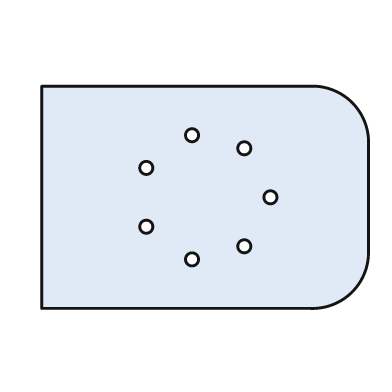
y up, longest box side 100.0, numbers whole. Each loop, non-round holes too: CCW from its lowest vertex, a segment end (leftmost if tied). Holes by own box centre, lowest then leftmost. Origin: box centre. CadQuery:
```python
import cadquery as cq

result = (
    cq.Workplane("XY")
    .moveTo(-50.0, -34.0)
    .lineTo(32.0, -34.0)
    .threePointArc((45.0, -29.0), (50.0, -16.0))
    .lineTo(50.0, 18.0)
    .threePointArc((45.0, 29.0), (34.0, 34.0))
    .lineTo(-50.0, 34.0)
    .close()
    .moveTo(-4.0, -19.0)
    .circle(2.0)
    .moveTo(12.0, -15.0)
    .circle(2.0)
    .moveTo(-18.0, -9.0)
    .circle(2.0)
    .moveTo(20.0, 0.0)
    .circle(2.0)
    .moveTo(-18.0, 9.0)
    .circle(2.0)
    .moveTo(12.0, 15.0)
    .circle(2.0)
    .moveTo(-4.0, 19.0)
    .circle(2.0)
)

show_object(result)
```